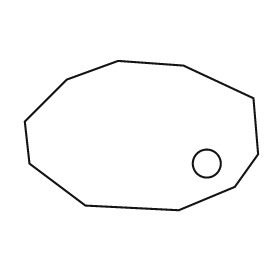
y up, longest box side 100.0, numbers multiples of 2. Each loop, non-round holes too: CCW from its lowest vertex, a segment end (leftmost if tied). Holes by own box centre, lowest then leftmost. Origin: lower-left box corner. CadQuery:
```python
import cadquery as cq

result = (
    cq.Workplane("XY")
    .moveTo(66.0, 0.0)
    .lineTo(90.0, 10.0)
    .lineTo(100.0, 24.0)
    .lineTo(98.0, 48.0)
    .lineTo(68.0, 62.0)
    .lineTo(40.0, 64.0)
    .lineTo(18.0, 56.0)
    .lineTo(0.0, 38.0)
    .lineTo(2.0, 20.0)
    .lineTo(26.0, 2.0)
    .close()
    .moveTo(78.0, 20.0)
    .circle(6.0)
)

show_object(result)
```